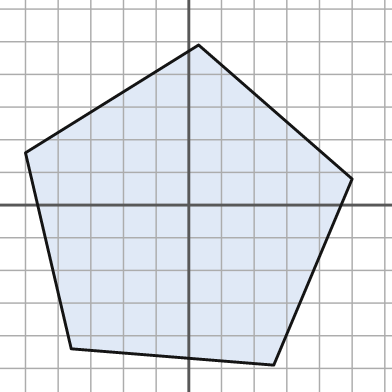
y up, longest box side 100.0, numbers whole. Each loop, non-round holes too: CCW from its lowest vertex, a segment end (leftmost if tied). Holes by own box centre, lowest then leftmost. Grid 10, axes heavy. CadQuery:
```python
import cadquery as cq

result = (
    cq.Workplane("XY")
    .moveTo(26.0, -49.0)
    .lineTo(50.0, 8.0)
    .lineTo(3.0, 49.0)
    .lineTo(-50.0, 16.0)
    .lineTo(-36.0, -44.0)
    .close()
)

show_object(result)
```